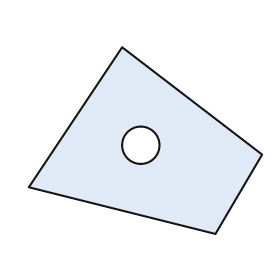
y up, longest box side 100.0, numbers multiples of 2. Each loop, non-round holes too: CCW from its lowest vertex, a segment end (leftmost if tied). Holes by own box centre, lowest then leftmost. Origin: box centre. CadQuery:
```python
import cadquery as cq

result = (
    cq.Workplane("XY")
    .moveTo(30.0, -40.0)
    .lineTo(50.0, -6.0)
    .lineTo(-10.0, 40.0)
    .lineTo(-50.0, -20.0)
    .close()
    .moveTo(-2.0, -2.0)
    .circle(8.0)
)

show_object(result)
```